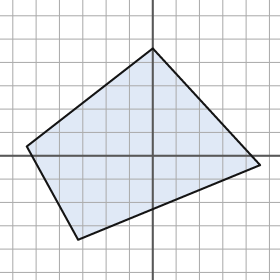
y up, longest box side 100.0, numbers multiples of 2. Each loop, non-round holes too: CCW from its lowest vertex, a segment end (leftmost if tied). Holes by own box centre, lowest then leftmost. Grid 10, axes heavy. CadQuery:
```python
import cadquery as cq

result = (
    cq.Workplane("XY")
    .moveTo(-32.0, -36.0)
    .lineTo(46.0, -4.0)
    .lineTo(0.0, 46.0)
    .lineTo(-54.0, 4.0)
    .close()
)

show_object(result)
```